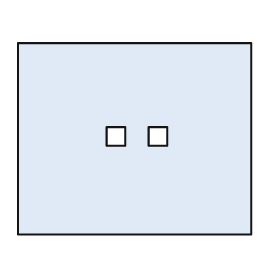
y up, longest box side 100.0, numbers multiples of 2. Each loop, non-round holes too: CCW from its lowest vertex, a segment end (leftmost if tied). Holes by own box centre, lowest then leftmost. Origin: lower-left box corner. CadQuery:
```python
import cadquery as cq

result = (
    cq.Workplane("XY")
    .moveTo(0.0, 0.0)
    .lineTo(100.0, 0.0)
    .lineTo(100.0, 82.0)
    .lineTo(0.0, 82.0)
    .close()
    .moveTo(38.0, 38.0)
    .lineTo(46.0, 38.0)
    .lineTo(46.0, 46.0)
    .lineTo(38.0, 46.0)
    .close()
    .moveTo(56.0, 38.0)
    .lineTo(64.0, 38.0)
    .lineTo(64.0, 46.0)
    .lineTo(56.0, 46.0)
    .close()
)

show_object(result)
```